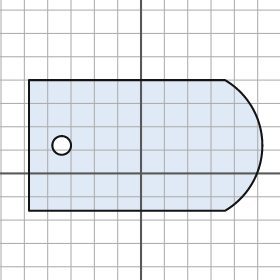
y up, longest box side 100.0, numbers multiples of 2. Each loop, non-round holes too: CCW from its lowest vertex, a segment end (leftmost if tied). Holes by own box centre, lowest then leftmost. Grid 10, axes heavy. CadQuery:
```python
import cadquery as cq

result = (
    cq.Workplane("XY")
    .moveTo(-48.0, -16.0)
    .lineTo(36.0, -16.0)
    .threePointArc((52.0, 12.0), (36.0, 40.0))
    .lineTo(-48.0, 40.0)
    .close()
    .moveTo(-34.0, 12.0)
    .circle(4.0)
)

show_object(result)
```